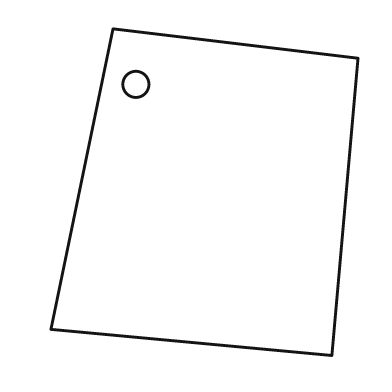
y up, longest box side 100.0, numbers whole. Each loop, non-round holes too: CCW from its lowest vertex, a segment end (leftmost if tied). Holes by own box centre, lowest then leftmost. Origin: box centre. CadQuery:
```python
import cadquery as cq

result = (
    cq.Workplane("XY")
    .moveTo(39.0, -50.0)
    .lineTo(47.0, 41.0)
    .lineTo(-28.0, 50.0)
    .lineTo(-47.0, -42.0)
    .close()
    .moveTo(-21.0, 33.0)
    .circle(4.0)
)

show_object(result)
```